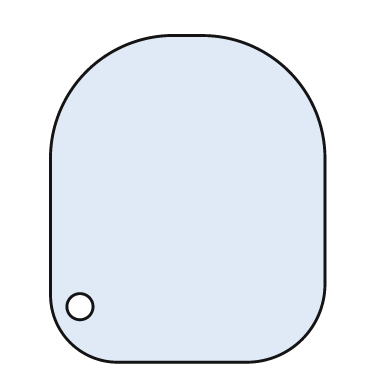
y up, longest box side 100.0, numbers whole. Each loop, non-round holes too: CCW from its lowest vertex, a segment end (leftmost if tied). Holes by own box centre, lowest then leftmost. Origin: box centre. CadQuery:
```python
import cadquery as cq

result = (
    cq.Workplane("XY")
    .moveTo(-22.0, -50.0)
    .lineTo(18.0, -50.0)
    .threePointArc((35.0, -43.0), (42.0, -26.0))
    .lineTo(42.0, 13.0)
    .threePointArc((31.0, 39.0), (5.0, 50.0))
    .lineTo(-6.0, 50.0)
    .threePointArc((-31.0, 39.0), (-42.0, 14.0))
    .lineTo(-42.0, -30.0)
    .threePointArc((-36.0, -44.0), (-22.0, -50.0))
    .close()
    .moveTo(-33.0, -33.0)
    .circle(4.0)
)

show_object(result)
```